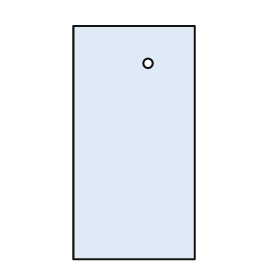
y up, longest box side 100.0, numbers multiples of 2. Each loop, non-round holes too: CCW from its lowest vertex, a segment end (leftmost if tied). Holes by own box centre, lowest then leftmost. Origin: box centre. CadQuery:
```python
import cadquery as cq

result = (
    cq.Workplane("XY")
    .moveTo(-26.0, -50.0)
    .lineTo(26.0, -50.0)
    .lineTo(26.0, 50.0)
    .lineTo(-26.0, 50.0)
    .close()
    .moveTo(6.0, 34.0)
    .circle(2.0)
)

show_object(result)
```